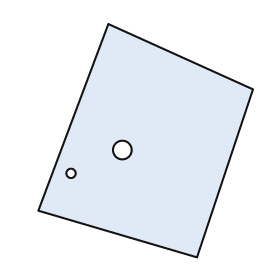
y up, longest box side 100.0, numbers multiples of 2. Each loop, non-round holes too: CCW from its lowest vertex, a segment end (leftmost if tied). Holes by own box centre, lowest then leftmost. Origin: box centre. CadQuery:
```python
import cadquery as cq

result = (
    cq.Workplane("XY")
    .moveTo(22.0, -50.0)
    .lineTo(46.0, 22.0)
    .lineTo(-16.0, 50.0)
    .lineTo(-46.0, -30.0)
    .close()
    .moveTo(-32.0, -14.0)
    .circle(2.0)
    .moveTo(-10.0, -4.0)
    .circle(4.0)
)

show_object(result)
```